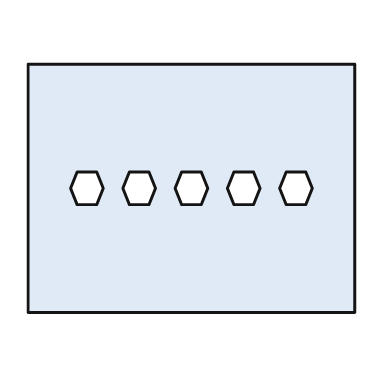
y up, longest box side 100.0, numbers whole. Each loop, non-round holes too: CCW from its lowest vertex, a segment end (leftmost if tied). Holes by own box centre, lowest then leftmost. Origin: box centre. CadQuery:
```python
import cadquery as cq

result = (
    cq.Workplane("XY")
    .moveTo(-50.0, -38.0)
    .lineTo(50.0, -38.0)
    .lineTo(50.0, 38.0)
    .lineTo(-50.0, 38.0)
    .close()
    .moveTo(-35.0, -5.0)
    .lineTo(-29.0, -5.0)
    .lineTo(-27.0, 0.0)
    .lineTo(-29.0, 5.0)
    .lineTo(-35.0, 5.0)
    .lineTo(-37.0, 0.0)
    .close()
    .moveTo(-19.0, -5.0)
    .lineTo(-13.0, -5.0)
    .lineTo(-11.0, 0.0)
    .lineTo(-13.0, 5.0)
    .lineTo(-19.0, 5.0)
    .lineTo(-21.0, 0.0)
    .close()
    .moveTo(-3.0, -5.0)
    .lineTo(3.0, -5.0)
    .lineTo(5.0, 0.0)
    .lineTo(3.0, 5.0)
    .lineTo(-3.0, 5.0)
    .lineTo(-5.0, 0.0)
    .close()
    .moveTo(13.0, -5.0)
    .lineTo(19.0, -5.0)
    .lineTo(21.0, 0.0)
    .lineTo(19.0, 5.0)
    .lineTo(13.0, 5.0)
    .lineTo(11.0, 0.0)
    .close()
    .moveTo(29.0, -5.0)
    .lineTo(35.0, -5.0)
    .lineTo(37.0, 0.0)
    .lineTo(35.0, 5.0)
    .lineTo(29.0, 5.0)
    .lineTo(27.0, 0.0)
    .close()
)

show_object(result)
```